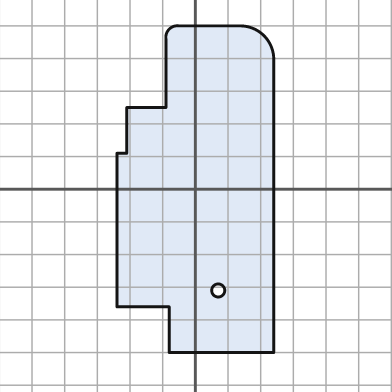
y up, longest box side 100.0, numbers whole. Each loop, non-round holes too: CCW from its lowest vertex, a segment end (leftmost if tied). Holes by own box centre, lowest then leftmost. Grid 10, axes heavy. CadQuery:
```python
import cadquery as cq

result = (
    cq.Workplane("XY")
    .moveTo(-8.0, -50.0)
    .lineTo(24.0, -50.0)
    .lineTo(24.0, 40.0)
    .threePointArc((21.0, 47.0), (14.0, 50.0))
    .lineTo(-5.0, 50.0)
    .threePointArc((-8.0, 49.0), (-9.0, 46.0))
    .lineTo(-9.0, 25.0)
    .lineTo(-21.0, 25.0)
    .lineTo(-21.0, 11.0)
    .lineTo(-24.0, 11.0)
    .lineTo(-24.0, -36.0)
    .lineTo(-8.0, -36.0)
    .close()
    .moveTo(7.0, -31.0)
    .circle(2.0)
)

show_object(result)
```